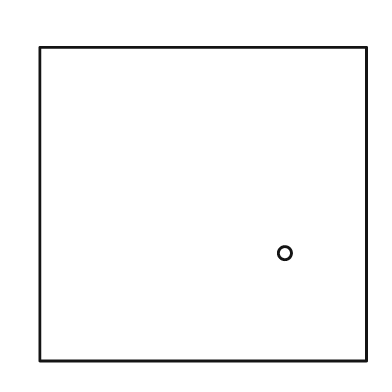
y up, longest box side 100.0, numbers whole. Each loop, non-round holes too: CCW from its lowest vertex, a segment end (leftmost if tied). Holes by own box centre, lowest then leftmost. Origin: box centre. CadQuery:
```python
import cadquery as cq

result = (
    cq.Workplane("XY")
    .moveTo(-50.0, -48.0)
    .lineTo(50.0, -48.0)
    .lineTo(50.0, 48.0)
    .lineTo(-50.0, 48.0)
    .close()
    .moveTo(25.0, -15.0)
    .circle(2.0)
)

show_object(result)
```